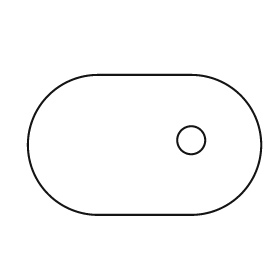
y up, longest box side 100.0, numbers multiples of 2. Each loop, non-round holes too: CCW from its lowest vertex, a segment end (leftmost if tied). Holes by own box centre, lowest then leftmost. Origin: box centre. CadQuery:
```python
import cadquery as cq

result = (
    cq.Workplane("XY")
    .moveTo(-20.0, -30.0)
    .lineTo(20.0, -30.0)
    .threePointArc((50.0, 0.0), (20.0, 30.0))
    .lineTo(-20.0, 30.0)
    .threePointArc((-50.0, 0.0), (-20.0, -30.0))
    .close()
    .moveTo(20.0, 2.0)
    .circle(6.0)
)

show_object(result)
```